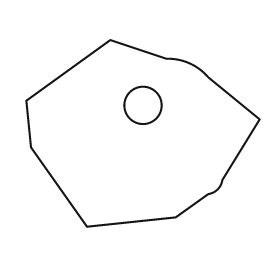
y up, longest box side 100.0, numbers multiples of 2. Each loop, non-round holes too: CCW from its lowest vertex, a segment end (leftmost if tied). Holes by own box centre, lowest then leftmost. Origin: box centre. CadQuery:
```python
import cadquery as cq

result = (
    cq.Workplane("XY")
    .moveTo(-24.0, -40.0)
    .lineTo(14.0, -36.0)
    .lineTo(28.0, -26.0)
    .threePointArc((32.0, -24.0), (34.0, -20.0))
    .lineTo(50.0, 6.0)
    .lineTo(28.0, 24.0)
    .threePointArc((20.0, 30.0), (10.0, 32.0))
    .lineTo(-14.0, 40.0)
    .lineTo(-50.0, 14.0)
    .lineTo(-48.0, -6.0)
    .close()
    .moveTo(0.0, 12.0)
    .circle(8.0)
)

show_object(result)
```